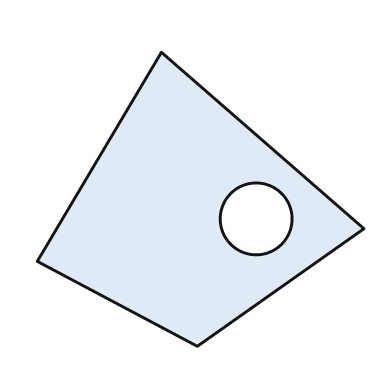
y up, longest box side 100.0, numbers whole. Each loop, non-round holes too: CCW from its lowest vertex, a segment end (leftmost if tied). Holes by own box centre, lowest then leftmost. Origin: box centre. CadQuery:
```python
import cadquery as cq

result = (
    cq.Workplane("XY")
    .moveTo(-1.0, -45.0)
    .lineTo(50.0, -9.0)
    .lineTo(-12.0, 45.0)
    .lineTo(-50.0, -19.0)
    .close()
    .moveTo(17.0, -6.0)
    .circle(11.0)
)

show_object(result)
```